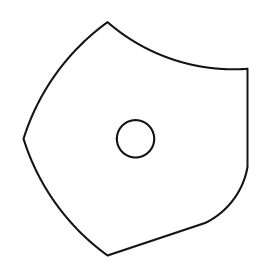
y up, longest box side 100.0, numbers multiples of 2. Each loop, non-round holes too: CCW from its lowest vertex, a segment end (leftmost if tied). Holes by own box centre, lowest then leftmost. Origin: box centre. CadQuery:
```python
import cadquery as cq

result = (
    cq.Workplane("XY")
    .moveTo(-12.0, -50.0)
    .lineTo(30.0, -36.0)
    .threePointArc((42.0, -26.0), (48.0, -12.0))
    .lineTo(48.0, 30.0)
    .threePointArc((16.0, 34.0), (-12.0, 50.0))
    .threePointArc((-34.0, 28.0), (-48.0, 0.0))
    .threePointArc((-34.0, -28.0), (-12.0, -50.0))
    .close()
    .moveTo(0.0, 0.0)
    .circle(8.0)
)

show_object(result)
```